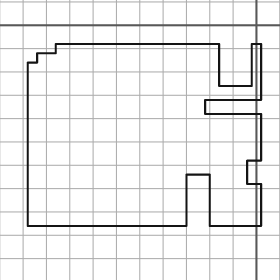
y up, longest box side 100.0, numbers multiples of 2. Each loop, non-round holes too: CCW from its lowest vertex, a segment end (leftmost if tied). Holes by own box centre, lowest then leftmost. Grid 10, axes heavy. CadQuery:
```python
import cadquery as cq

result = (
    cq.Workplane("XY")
    .moveTo(-98.0, -86.0)
    .lineTo(-30.0, -86.0)
    .lineTo(-30.0, -64.0)
    .lineTo(-20.0, -64.0)
    .lineTo(-20.0, -86.0)
    .lineTo(2.0, -86.0)
    .lineTo(2.0, -68.0)
    .lineTo(-4.0, -68.0)
    .lineTo(-4.0, -58.0)
    .lineTo(2.0, -58.0)
    .lineTo(2.0, -38.0)
    .lineTo(-22.0, -38.0)
    .lineTo(-22.0, -32.0)
    .lineTo(2.0, -32.0)
    .lineTo(2.0, -8.0)
    .lineTo(-2.0, -8.0)
    .lineTo(-2.0, -26.0)
    .lineTo(-16.0, -26.0)
    .lineTo(-16.0, -8.0)
    .lineTo(-86.0, -8.0)
    .lineTo(-86.0, -12.0)
    .lineTo(-94.0, -12.0)
    .lineTo(-94.0, -16.0)
    .lineTo(-98.0, -16.0)
    .close()
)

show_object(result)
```